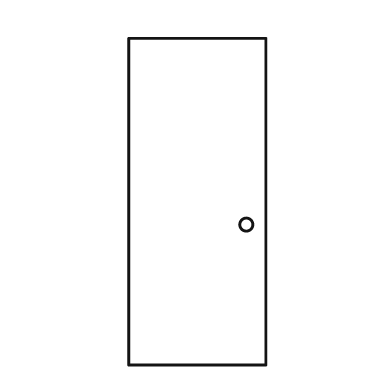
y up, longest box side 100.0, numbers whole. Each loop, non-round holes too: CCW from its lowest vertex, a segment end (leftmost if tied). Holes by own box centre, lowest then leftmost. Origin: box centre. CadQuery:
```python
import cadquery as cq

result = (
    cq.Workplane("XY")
    .moveTo(-21.0, -50.0)
    .lineTo(21.0, -50.0)
    .lineTo(21.0, 50.0)
    .lineTo(-21.0, 50.0)
    .close()
    .moveTo(15.0, -7.0)
    .circle(2.0)
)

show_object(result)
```